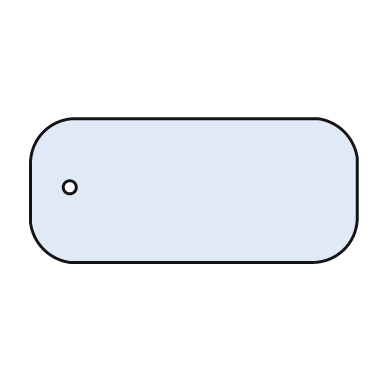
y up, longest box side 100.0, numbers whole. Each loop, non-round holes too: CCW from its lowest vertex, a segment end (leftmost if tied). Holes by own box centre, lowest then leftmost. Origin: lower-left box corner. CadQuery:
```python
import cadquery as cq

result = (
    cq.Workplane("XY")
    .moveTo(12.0, 0.0)
    .lineTo(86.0, 0.0)
    .threePointArc((96.0, 4.0), (100.0, 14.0))
    .lineTo(100.0, 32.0)
    .threePointArc((96.0, 40.0), (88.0, 44.0))
    .lineTo(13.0, 44.0)
    .threePointArc((4.0, 40.0), (0.0, 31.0))
    .lineTo(0.0, 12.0)
    .threePointArc((4.0, 4.0), (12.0, 0.0))
    .close()
    .moveTo(12.0, 23.0)
    .circle(2.0)
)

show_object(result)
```